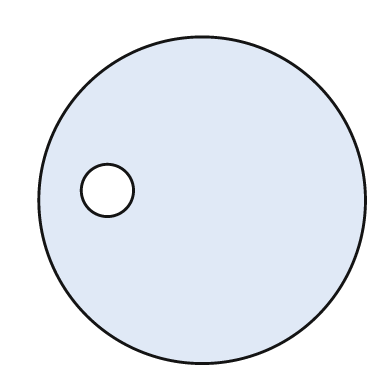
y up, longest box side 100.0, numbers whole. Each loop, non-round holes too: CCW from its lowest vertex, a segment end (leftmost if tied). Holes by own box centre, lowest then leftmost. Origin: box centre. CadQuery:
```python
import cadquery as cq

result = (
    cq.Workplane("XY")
    .moveTo(0.0, 0.0)
    .circle(50.0)
    .moveTo(-29.0, 3.0)
    .circle(8.0)
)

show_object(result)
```